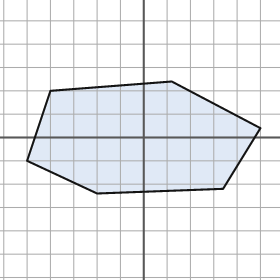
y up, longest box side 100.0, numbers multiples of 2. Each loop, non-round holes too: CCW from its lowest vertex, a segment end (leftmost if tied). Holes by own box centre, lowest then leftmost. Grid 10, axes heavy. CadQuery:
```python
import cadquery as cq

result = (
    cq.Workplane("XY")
    .moveTo(-20.0, -24.0)
    .lineTo(34.0, -22.0)
    .lineTo(50.0, 4.0)
    .lineTo(12.0, 24.0)
    .lineTo(-40.0, 20.0)
    .lineTo(-50.0, -10.0)
    .close()
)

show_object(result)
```